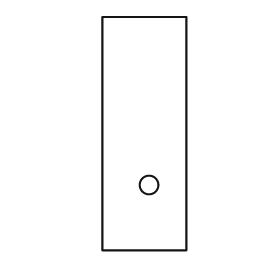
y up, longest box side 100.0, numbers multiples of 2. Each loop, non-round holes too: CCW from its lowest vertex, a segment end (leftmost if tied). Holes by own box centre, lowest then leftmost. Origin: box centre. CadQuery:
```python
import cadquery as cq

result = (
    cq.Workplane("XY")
    .moveTo(-18.0, -50.0)
    .lineTo(18.0, -50.0)
    .lineTo(18.0, 50.0)
    .lineTo(-18.0, 50.0)
    .close()
    .moveTo(2.0, -22.0)
    .circle(4.0)
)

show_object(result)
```